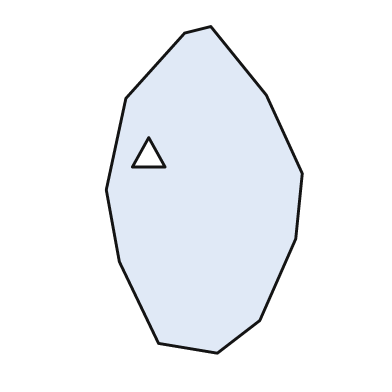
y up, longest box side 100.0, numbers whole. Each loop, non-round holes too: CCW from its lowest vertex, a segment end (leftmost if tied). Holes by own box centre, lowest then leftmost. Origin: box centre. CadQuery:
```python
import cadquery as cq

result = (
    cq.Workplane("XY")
    .moveTo(4.0, -50.0)
    .lineTo(17.0, -40.0)
    .lineTo(28.0, -15.0)
    .lineTo(30.0, 5.0)
    .lineTo(19.0, 29.0)
    .lineTo(2.0, 50.0)
    .lineTo(-6.0, 48.0)
    .lineTo(-24.0, 28.0)
    .lineTo(-30.0, 0.0)
    .lineTo(-26.0, -22.0)
    .lineTo(-14.0, -47.0)
    .close()
    .moveTo(-22.0, 7.0)
    .lineTo(-12.0, 7.0)
    .lineTo(-17.0, 16.0)
    .close()
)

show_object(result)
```